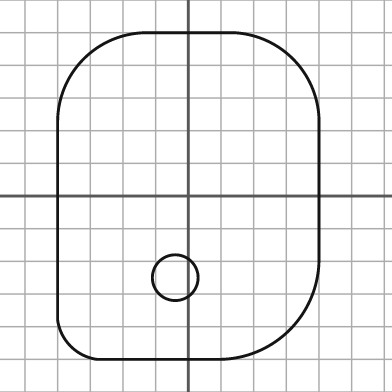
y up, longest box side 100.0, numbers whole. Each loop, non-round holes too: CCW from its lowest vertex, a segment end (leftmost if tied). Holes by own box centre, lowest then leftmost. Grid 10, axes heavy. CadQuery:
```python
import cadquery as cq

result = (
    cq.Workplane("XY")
    .moveTo(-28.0, -50.0)
    .lineTo(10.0, -50.0)
    .threePointArc((31.0, -41.0), (40.0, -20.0))
    .lineTo(40.0, 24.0)
    .threePointArc((32.0, 42.0), (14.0, 50.0))
    .lineTo(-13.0, 50.0)
    .threePointArc((-32.0, 42.0), (-40.0, 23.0))
    .lineTo(-40.0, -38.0)
    .threePointArc((-36.0, -46.0), (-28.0, -50.0))
    .close()
    .moveTo(-4.0, -25.0)
    .circle(7.0)
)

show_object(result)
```